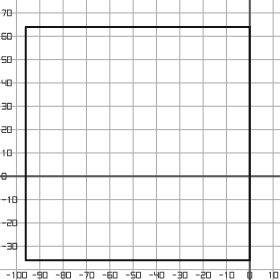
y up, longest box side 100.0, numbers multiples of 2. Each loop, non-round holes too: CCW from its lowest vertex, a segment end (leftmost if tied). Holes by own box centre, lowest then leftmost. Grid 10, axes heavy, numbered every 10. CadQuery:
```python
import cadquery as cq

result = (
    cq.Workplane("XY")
    .moveTo(-96.0, -36.0)
    .lineTo(0.0, -36.0)
    .lineTo(0.0, 64.0)
    .lineTo(-96.0, 64.0)
    .close()
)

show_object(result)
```